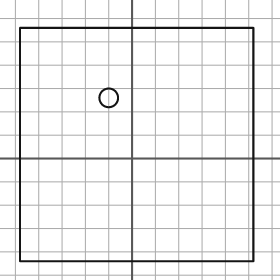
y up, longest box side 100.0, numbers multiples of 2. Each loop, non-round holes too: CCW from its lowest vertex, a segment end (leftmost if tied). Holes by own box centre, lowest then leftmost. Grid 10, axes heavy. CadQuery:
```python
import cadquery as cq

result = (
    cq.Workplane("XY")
    .moveTo(-48.0, -44.0)
    .lineTo(52.0, -44.0)
    .lineTo(52.0, 56.0)
    .lineTo(-48.0, 56.0)
    .close()
    .moveTo(-10.0, 26.0)
    .circle(4.0)
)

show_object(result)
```